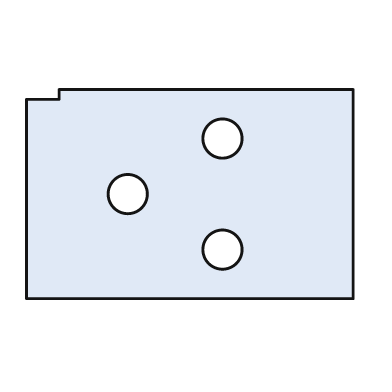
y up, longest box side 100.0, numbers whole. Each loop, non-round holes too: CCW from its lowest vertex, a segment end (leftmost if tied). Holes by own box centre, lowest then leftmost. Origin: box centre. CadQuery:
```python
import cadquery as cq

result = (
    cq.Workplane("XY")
    .moveTo(-50.0, -32.0)
    .lineTo(50.0, -32.0)
    .lineTo(50.0, 32.0)
    .lineTo(-40.0, 32.0)
    .lineTo(-40.0, 29.0)
    .lineTo(-50.0, 29.0)
    .close()
    .moveTo(10.0, -17.0)
    .circle(6.0)
    .moveTo(-19.0, 0.0)
    .circle(6.0)
    .moveTo(10.0, 17.0)
    .circle(6.0)
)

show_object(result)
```